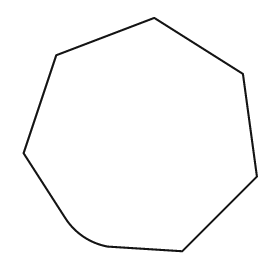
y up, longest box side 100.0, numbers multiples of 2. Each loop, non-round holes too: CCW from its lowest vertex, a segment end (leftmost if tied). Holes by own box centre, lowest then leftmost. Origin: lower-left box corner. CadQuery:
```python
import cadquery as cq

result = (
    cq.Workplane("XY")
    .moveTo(68.0, 0.0)
    .lineTo(100.0, 32.0)
    .lineTo(94.0, 76.0)
    .lineTo(56.0, 100.0)
    .lineTo(14.0, 84.0)
    .lineTo(0.0, 42.0)
    .lineTo(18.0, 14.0)
    .threePointArc((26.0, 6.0), (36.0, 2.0))
    .close()
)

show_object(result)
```